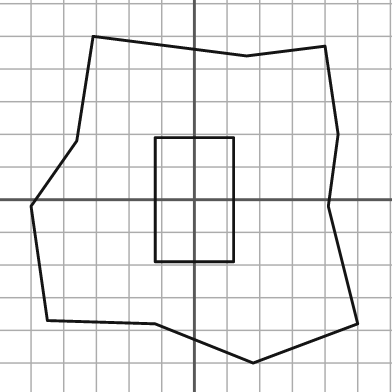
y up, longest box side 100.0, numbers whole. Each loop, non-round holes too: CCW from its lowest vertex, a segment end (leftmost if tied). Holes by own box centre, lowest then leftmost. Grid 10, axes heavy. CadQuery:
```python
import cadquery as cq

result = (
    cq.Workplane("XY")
    .moveTo(18.0, -50.0)
    .lineTo(50.0, -38.0)
    .lineTo(41.0, -2.0)
    .lineTo(44.0, 20.0)
    .lineTo(40.0, 47.0)
    .lineTo(16.0, 44.0)
    .lineTo(-31.0, 50.0)
    .lineTo(-36.0, 18.0)
    .lineTo(-50.0, -2.0)
    .lineTo(-45.0, -37.0)
    .lineTo(-12.0, -38.0)
    .close()
    .moveTo(-12.0, -19.0)
    .lineTo(12.0, -19.0)
    .lineTo(12.0, 19.0)
    .lineTo(-12.0, 19.0)
    .close()
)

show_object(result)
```